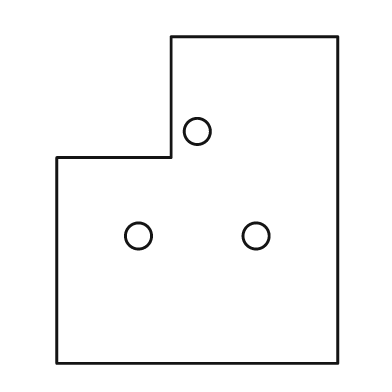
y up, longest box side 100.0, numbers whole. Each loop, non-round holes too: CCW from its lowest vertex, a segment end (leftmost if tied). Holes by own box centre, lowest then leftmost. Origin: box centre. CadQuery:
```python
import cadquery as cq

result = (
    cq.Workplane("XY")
    .moveTo(-43.0, -50.0)
    .lineTo(43.0, -50.0)
    .lineTo(43.0, 50.0)
    .lineTo(-8.0, 50.0)
    .lineTo(-8.0, 13.0)
    .lineTo(-43.0, 13.0)
    .close()
    .moveTo(-18.0, -11.0)
    .circle(4.0)
    .moveTo(18.0, -11.0)
    .circle(4.0)
    .moveTo(0.0, 21.0)
    .circle(4.0)
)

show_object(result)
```